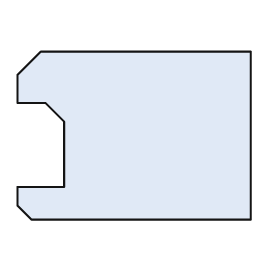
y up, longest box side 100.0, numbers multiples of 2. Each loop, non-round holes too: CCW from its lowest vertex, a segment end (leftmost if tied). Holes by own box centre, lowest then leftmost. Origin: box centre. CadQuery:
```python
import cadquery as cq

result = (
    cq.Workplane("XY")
    .moveTo(-44.0, -36.0)
    .lineTo(50.0, -36.0)
    .lineTo(50.0, 36.0)
    .lineTo(-40.0, 36.0)
    .lineTo(-50.0, 26.0)
    .lineTo(-50.0, 14.0)
    .lineTo(-38.0, 14.0)
    .lineTo(-30.0, 6.0)
    .lineTo(-30.0, -22.0)
    .lineTo(-50.0, -22.0)
    .lineTo(-50.0, -30.0)
    .close()
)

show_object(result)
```